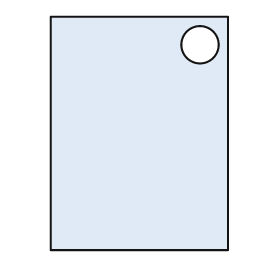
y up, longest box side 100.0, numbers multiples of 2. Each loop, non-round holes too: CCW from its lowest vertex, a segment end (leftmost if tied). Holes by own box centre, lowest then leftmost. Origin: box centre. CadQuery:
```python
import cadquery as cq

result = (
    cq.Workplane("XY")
    .moveTo(-38.0, -50.0)
    .lineTo(38.0, -50.0)
    .lineTo(38.0, 50.0)
    .lineTo(-38.0, 50.0)
    .close()
    .moveTo(26.0, 38.0)
    .circle(8.0)
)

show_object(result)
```